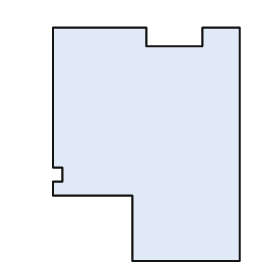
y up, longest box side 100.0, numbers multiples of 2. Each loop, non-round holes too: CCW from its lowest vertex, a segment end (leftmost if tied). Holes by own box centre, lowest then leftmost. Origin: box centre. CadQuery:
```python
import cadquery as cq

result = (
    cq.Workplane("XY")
    .moveTo(-6.0, -50.0)
    .lineTo(40.0, -50.0)
    .lineTo(40.0, 50.0)
    .lineTo(24.0, 50.0)
    .lineTo(24.0, 42.0)
    .lineTo(0.0, 42.0)
    .lineTo(0.0, 50.0)
    .lineTo(-40.0, 50.0)
    .lineTo(-40.0, -10.0)
    .lineTo(-36.0, -10.0)
    .lineTo(-36.0, -16.0)
    .lineTo(-40.0, -16.0)
    .lineTo(-40.0, -22.0)
    .lineTo(-6.0, -22.0)
    .close()
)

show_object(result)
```